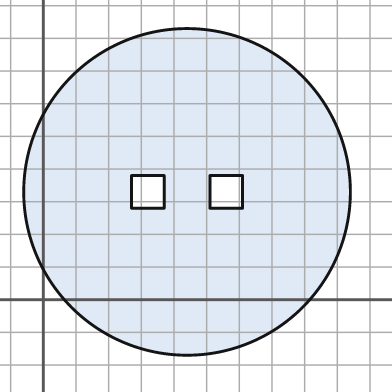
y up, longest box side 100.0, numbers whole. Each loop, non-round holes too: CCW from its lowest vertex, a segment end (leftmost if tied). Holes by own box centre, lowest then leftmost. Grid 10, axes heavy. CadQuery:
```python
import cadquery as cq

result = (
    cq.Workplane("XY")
    .moveTo(44.0, 33.0)
    .circle(50.0)
    .moveTo(27.0, 28.0)
    .lineTo(37.0, 28.0)
    .lineTo(37.0, 38.0)
    .lineTo(27.0, 38.0)
    .close()
    .moveTo(51.0, 28.0)
    .lineTo(61.0, 28.0)
    .lineTo(61.0, 38.0)
    .lineTo(51.0, 38.0)
    .close()
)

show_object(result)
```